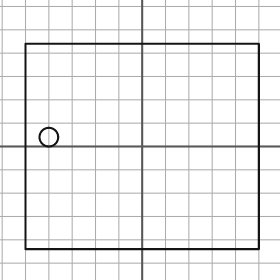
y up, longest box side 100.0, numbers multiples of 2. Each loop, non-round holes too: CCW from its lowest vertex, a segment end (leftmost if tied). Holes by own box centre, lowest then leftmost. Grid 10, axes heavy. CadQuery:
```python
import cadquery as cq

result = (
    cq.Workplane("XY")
    .moveTo(-50.0, -44.0)
    .lineTo(50.0, -44.0)
    .lineTo(50.0, 44.0)
    .lineTo(-50.0, 44.0)
    .close()
    .moveTo(-40.0, 4.0)
    .circle(4.0)
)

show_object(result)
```